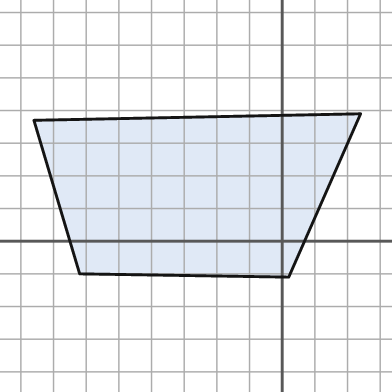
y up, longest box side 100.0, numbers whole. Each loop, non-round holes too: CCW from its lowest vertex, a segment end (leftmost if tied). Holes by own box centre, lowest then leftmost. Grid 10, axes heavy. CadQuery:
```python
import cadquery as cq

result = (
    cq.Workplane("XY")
    .moveTo(2.0, -11.0)
    .lineTo(24.0, 39.0)
    .lineTo(-76.0, 37.0)
    .lineTo(-62.0, -10.0)
    .close()
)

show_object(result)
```